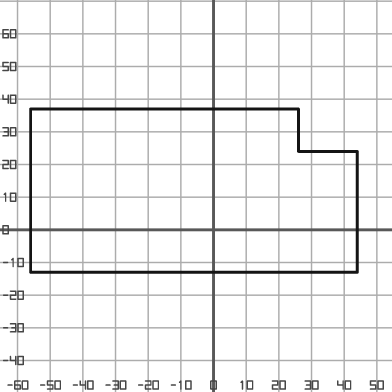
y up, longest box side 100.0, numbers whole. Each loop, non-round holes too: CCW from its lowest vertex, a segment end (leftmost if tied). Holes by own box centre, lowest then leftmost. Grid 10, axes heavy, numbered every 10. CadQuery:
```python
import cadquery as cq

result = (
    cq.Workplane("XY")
    .moveTo(-56.0, -13.0)
    .lineTo(44.0, -13.0)
    .lineTo(44.0, 24.0)
    .lineTo(26.0, 24.0)
    .lineTo(26.0, 37.0)
    .lineTo(-56.0, 37.0)
    .close()
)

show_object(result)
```